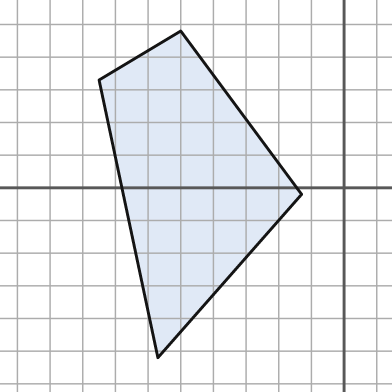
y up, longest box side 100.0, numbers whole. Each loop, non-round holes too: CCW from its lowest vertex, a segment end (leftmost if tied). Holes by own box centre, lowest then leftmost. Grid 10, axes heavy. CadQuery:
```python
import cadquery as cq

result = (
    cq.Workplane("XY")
    .moveTo(-57.0, -52.0)
    .lineTo(-13.0, -2.0)
    .lineTo(-50.0, 48.0)
    .lineTo(-75.0, 33.0)
    .close()
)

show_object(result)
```